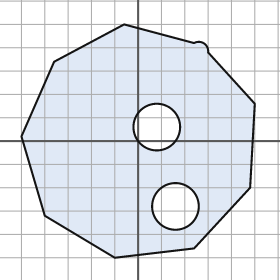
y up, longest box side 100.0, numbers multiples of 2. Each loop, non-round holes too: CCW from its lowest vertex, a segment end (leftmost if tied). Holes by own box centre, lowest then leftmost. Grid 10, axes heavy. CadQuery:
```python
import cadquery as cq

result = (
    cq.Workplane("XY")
    .moveTo(-10.0, -50.0)
    .lineTo(24.0, -46.0)
    .lineTo(48.0, -20.0)
    .lineTo(50.0, 16.0)
    .lineTo(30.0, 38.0)
    .threePointArc((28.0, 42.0), (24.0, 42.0))
    .lineTo(-6.0, 50.0)
    .lineTo(-36.0, 34.0)
    .lineTo(-50.0, 2.0)
    .lineTo(-40.0, -32.0)
    .close()
    .moveTo(16.0, -28.0)
    .circle(10.0)
    .moveTo(8.0, 6.0)
    .circle(10.0)
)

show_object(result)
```